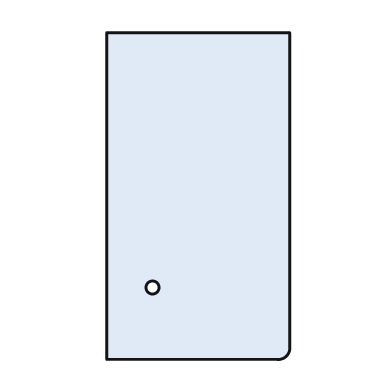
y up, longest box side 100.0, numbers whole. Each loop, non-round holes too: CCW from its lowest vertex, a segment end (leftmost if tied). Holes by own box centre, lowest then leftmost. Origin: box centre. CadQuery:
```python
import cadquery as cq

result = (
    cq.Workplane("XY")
    .moveTo(-28.0, -50.0)
    .lineTo(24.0, -50.0)
    .threePointArc((27.0, -49.0), (28.0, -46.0))
    .lineTo(28.0, 50.0)
    .lineTo(-28.0, 50.0)
    .close()
    .moveTo(-14.0, -28.0)
    .circle(2.0)
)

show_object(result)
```